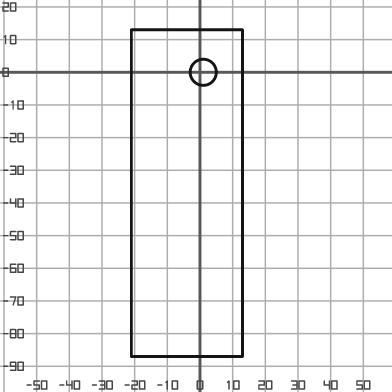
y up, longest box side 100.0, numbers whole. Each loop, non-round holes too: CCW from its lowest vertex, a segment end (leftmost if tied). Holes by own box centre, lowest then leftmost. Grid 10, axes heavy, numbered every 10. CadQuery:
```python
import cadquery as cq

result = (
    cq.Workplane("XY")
    .moveTo(-21.0, -87.0)
    .lineTo(13.0, -87.0)
    .lineTo(13.0, 13.0)
    .lineTo(-21.0, 13.0)
    .close()
    .moveTo(1.0, 0.0)
    .circle(4.0)
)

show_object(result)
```